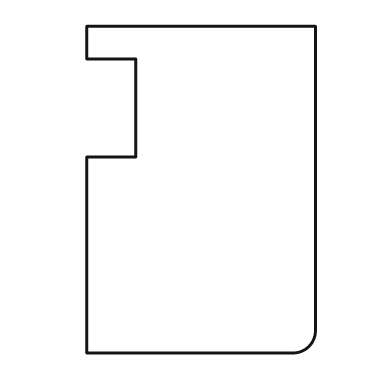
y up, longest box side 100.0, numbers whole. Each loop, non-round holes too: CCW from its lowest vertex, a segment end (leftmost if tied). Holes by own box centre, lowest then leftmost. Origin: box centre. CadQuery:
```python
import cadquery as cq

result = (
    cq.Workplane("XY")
    .moveTo(-35.0, -50.0)
    .lineTo(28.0, -50.0)
    .threePointArc((33.0, -48.0), (35.0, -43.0))
    .lineTo(35.0, 50.0)
    .lineTo(-35.0, 50.0)
    .lineTo(-35.0, 40.0)
    .lineTo(-20.0, 40.0)
    .lineTo(-20.0, 10.0)
    .lineTo(-35.0, 10.0)
    .close()
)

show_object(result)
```